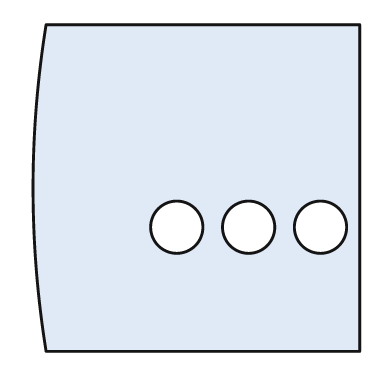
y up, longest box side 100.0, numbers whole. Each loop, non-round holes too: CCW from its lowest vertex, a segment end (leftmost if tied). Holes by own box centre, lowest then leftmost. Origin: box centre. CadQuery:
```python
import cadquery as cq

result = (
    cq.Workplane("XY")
    .moveTo(-46.0, -50.0)
    .lineTo(50.0, -50.0)
    .lineTo(50.0, 50.0)
    .lineTo(-46.0, 50.0)
    .threePointArc((-50.0, 0.0), (-46.0, -50.0))
    .close()
    .moveTo(-6.0, -12.0)
    .circle(8.0)
    .moveTo(16.0, -12.0)
    .circle(8.0)
    .moveTo(38.0, -12.0)
    .circle(8.0)
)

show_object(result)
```